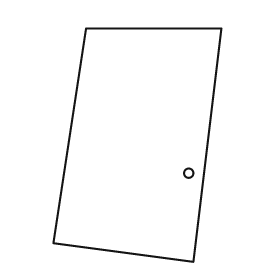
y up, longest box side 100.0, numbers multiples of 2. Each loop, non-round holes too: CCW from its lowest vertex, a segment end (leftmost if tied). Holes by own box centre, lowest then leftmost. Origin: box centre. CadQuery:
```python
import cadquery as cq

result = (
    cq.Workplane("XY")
    .moveTo(24.0, -50.0)
    .lineTo(36.0, 50.0)
    .lineTo(-22.0, 50.0)
    .lineTo(-36.0, -42.0)
    .close()
    .moveTo(22.0, -12.0)
    .circle(2.0)
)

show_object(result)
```